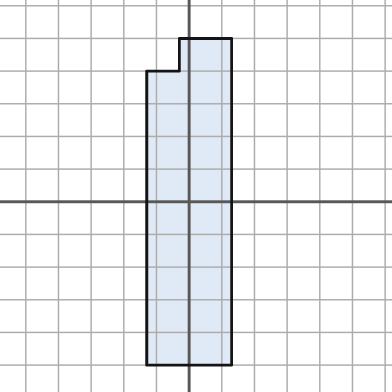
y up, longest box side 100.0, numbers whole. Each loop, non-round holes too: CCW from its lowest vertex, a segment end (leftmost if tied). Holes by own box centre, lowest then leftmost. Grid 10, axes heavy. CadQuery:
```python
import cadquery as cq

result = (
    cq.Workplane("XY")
    .moveTo(-13.0, -50.0)
    .lineTo(13.0, -50.0)
    .lineTo(13.0, 50.0)
    .lineTo(-3.0, 50.0)
    .lineTo(-3.0, 40.0)
    .lineTo(-13.0, 40.0)
    .close()
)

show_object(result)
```